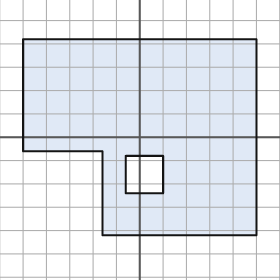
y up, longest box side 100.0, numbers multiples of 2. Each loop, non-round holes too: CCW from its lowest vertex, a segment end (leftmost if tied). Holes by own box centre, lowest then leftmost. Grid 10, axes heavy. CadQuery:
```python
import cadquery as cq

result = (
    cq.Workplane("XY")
    .moveTo(-16.0, -42.0)
    .lineTo(50.0, -42.0)
    .lineTo(50.0, 42.0)
    .lineTo(-50.0, 42.0)
    .lineTo(-50.0, -6.0)
    .lineTo(-16.0, -6.0)
    .close()
    .moveTo(-6.0, -24.0)
    .lineTo(10.0, -24.0)
    .lineTo(10.0, -8.0)
    .lineTo(-6.0, -8.0)
    .close()
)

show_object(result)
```